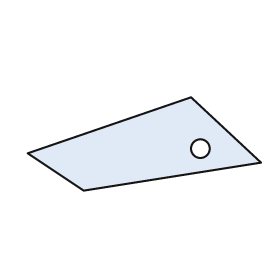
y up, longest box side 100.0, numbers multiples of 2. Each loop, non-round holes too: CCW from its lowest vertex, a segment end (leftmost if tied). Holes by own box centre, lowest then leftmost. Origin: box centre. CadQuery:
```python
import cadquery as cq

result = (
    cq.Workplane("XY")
    .moveTo(-26.0, -20.0)
    .lineTo(50.0, -8.0)
    .lineTo(20.0, 20.0)
    .lineTo(-50.0, -4.0)
    .close()
    .moveTo(24.0, -2.0)
    .circle(4.0)
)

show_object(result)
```